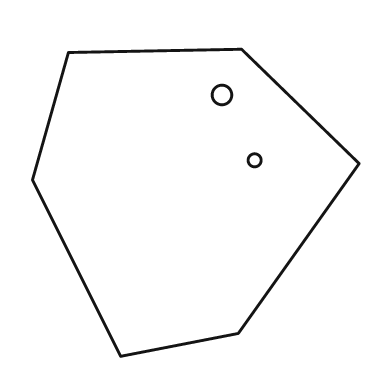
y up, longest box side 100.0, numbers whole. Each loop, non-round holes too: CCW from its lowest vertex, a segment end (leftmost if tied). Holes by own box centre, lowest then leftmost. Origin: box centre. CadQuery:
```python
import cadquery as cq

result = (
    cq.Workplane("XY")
    .moveTo(-23.0, -47.0)
    .lineTo(13.0, -40.0)
    .lineTo(50.0, 12.0)
    .lineTo(14.0, 47.0)
    .lineTo(-39.0, 46.0)
    .lineTo(-50.0, 7.0)
    .close()
    .moveTo(18.0, 13.0)
    .circle(2.0)
    .moveTo(8.0, 33.0)
    .circle(3.0)
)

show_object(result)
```